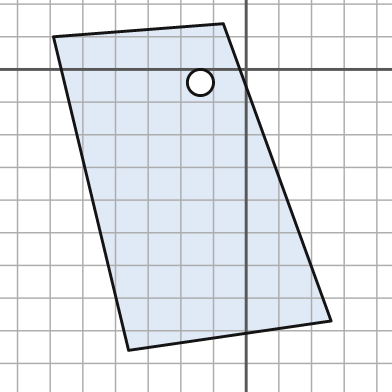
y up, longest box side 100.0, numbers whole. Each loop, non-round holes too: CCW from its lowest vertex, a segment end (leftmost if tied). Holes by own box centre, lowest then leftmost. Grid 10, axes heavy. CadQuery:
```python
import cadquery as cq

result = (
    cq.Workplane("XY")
    .moveTo(-36.0, -86.0)
    .lineTo(26.0, -77.0)
    .lineTo(-7.0, 14.0)
    .lineTo(-59.0, 10.0)
    .close()
    .moveTo(-14.0, -4.0)
    .circle(4.0)
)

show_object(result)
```